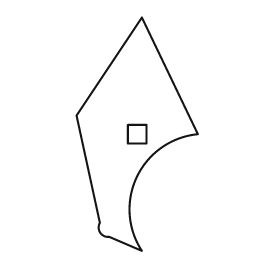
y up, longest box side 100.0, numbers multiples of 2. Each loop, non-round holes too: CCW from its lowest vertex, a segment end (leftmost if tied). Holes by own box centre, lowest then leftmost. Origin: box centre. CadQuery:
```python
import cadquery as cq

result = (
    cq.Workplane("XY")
    .moveTo(2.0, -50.0)
    .threePointArc((0.0, -18.0), (26.0, 0.0))
    .lineTo(2.0, 50.0)
    .lineTo(-26.0, 8.0)
    .lineTo(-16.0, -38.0)
    .threePointArc((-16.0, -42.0), (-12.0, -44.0))
    .close()
    .moveTo(-4.0, -4.0)
    .lineTo(4.0, -4.0)
    .lineTo(4.0, 4.0)
    .lineTo(-4.0, 4.0)
    .close()
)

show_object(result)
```